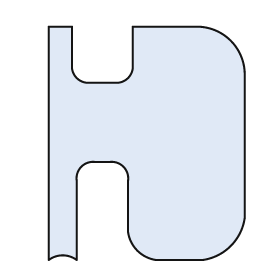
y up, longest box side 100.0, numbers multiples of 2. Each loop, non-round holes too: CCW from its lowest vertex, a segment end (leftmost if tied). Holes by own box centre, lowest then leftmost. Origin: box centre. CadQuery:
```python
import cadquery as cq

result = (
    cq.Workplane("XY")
    .moveTo(-42.0, -50.0)
    .threePointArc((-36.0, -48.0), (-30.0, -50.0))
    .lineTo(-30.0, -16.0)
    .threePointArc((-28.0, -10.0), (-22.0, -8.0))
    .lineTo(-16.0, -8.0)
    .threePointArc((-10.0, -10.0), (-8.0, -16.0))
    .lineTo(-8.0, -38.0)
    .threePointArc((-4.0, -46.0), (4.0, -50.0))
    .lineTo(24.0, -50.0)
    .threePointArc((36.0, -44.0), (42.0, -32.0))
    .lineTo(42.0, 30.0)
    .threePointArc((36.0, 44.0), (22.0, 50.0))
    .lineTo(-6.0, 50.0)
    .lineTo(-6.0, 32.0)
    .threePointArc((-8.0, 28.0), (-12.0, 26.0))
    .lineTo(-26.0, 26.0)
    .threePointArc((-30.0, 28.0), (-32.0, 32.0))
    .lineTo(-32.0, 50.0)
    .lineTo(-42.0, 50.0)
    .close()
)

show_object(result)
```